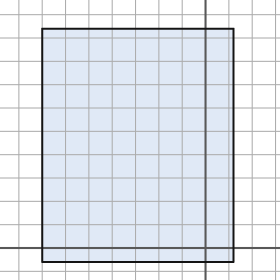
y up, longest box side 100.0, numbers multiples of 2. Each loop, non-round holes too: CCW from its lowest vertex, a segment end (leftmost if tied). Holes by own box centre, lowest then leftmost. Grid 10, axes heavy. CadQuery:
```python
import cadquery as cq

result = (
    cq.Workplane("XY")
    .moveTo(-70.0, -6.0)
    .lineTo(12.0, -6.0)
    .lineTo(12.0, 94.0)
    .lineTo(-70.0, 94.0)
    .close()
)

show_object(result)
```